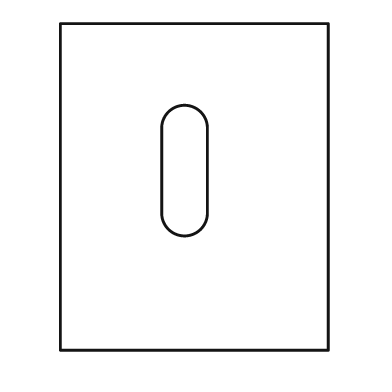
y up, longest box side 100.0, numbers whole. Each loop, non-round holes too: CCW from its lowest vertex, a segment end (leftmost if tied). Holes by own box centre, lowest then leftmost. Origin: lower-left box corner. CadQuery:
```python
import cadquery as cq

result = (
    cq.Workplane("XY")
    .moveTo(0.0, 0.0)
    .lineTo(82.0, 0.0)
    .lineTo(82.0, 100.0)
    .lineTo(0.0, 100.0)
    .close()
    .moveTo(31.0, 42.0)
    .threePointArc((38.0, 35.0), (45.0, 42.0))
    .lineTo(45.0, 68.0)
    .threePointArc((38.0, 75.0), (31.0, 68.0))
    .close()
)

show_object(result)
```